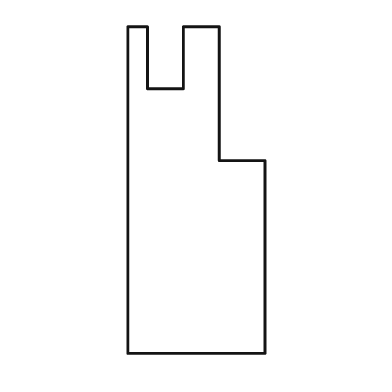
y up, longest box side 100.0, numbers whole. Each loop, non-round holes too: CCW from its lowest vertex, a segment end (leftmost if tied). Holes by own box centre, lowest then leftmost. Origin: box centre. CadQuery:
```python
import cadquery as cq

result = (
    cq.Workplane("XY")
    .moveTo(-21.0, -50.0)
    .lineTo(21.0, -50.0)
    .lineTo(21.0, 9.0)
    .lineTo(7.0, 9.0)
    .lineTo(7.0, 50.0)
    .lineTo(-4.0, 50.0)
    .lineTo(-4.0, 31.0)
    .lineTo(-15.0, 31.0)
    .lineTo(-15.0, 50.0)
    .lineTo(-21.0, 50.0)
    .close()
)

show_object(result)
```